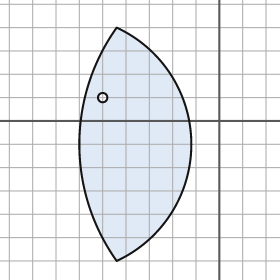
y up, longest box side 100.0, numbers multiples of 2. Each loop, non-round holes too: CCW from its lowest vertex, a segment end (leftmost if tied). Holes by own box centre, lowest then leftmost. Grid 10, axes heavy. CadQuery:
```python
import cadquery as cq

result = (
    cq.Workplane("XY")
    .moveTo(-44.0, -60.0)
    .threePointArc((-12.0, -10.0), (-44.0, 40.0))
    .threePointArc((-60.0, -10.0), (-44.0, -60.0))
    .close()
    .moveTo(-50.0, 10.0)
    .circle(2.0)
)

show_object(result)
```